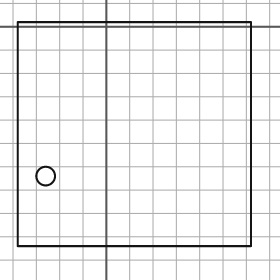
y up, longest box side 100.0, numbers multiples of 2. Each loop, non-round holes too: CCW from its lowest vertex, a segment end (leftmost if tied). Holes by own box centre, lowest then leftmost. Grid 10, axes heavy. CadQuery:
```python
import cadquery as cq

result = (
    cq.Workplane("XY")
    .moveTo(-38.0, -94.0)
    .lineTo(62.0, -94.0)
    .lineTo(62.0, 2.0)
    .lineTo(-38.0, 2.0)
    .close()
    .moveTo(-26.0, -64.0)
    .circle(4.0)
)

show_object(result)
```